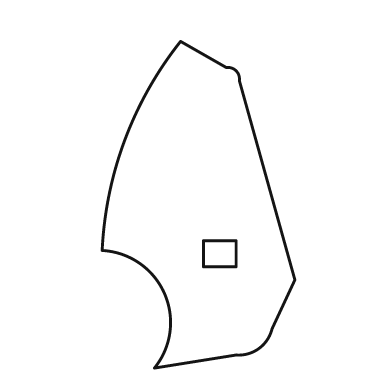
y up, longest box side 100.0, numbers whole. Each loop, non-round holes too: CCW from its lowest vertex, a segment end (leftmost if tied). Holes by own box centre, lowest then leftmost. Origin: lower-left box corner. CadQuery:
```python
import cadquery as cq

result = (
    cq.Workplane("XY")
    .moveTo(16.0, 0.0)
    .lineTo(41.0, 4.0)
    .threePointArc((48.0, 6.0), (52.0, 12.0))
    .lineTo(59.0, 27.0)
    .lineTo(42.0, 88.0)
    .threePointArc((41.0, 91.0), (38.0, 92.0))
    .lineTo(24.0, 100.0)
    .threePointArc((7.0, 70.0), (0.0, 36.0))
    .threePointArc((19.0, 23.0), (16.0, 0.0))
    .close()
    .moveTo(31.0, 31.0)
    .lineTo(41.0, 31.0)
    .lineTo(41.0, 39.0)
    .lineTo(31.0, 39.0)
    .close()
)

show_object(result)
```